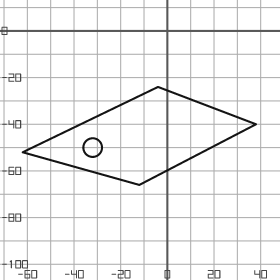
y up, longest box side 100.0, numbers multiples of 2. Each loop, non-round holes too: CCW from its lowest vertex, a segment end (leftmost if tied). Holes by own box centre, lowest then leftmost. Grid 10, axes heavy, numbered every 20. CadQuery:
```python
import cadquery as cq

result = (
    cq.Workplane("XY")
    .moveTo(-12.0, -66.0)
    .lineTo(38.0, -40.0)
    .lineTo(-4.0, -24.0)
    .lineTo(-62.0, -52.0)
    .close()
    .moveTo(-32.0, -50.0)
    .circle(4.0)
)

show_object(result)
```